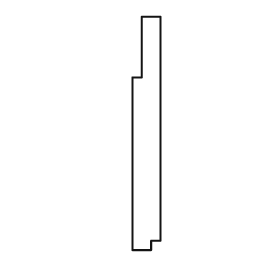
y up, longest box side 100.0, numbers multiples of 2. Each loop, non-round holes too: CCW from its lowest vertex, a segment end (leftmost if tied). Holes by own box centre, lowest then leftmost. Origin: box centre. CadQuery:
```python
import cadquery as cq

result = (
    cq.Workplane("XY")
    .moveTo(-6.0, -50.0)
    .lineTo(2.0, -50.0)
    .lineTo(2.0, -46.0)
    .lineTo(6.0, -46.0)
    .lineTo(6.0, 50.0)
    .lineTo(-2.0, 50.0)
    .lineTo(-2.0, 24.0)
    .lineTo(-6.0, 24.0)
    .close()
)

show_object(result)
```